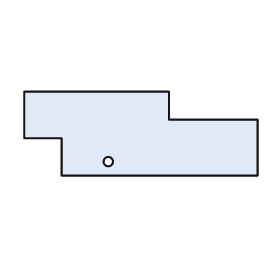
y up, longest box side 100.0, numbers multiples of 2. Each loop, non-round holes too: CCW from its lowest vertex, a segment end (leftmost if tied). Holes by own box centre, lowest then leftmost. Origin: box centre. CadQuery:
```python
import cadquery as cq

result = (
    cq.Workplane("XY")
    .moveTo(-34.0, -18.0)
    .lineTo(50.0, -18.0)
    .lineTo(50.0, 6.0)
    .lineTo(12.0, 6.0)
    .lineTo(12.0, 18.0)
    .lineTo(-50.0, 18.0)
    .lineTo(-50.0, -2.0)
    .lineTo(-34.0, -2.0)
    .close()
    .moveTo(-14.0, -12.0)
    .circle(2.0)
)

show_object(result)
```